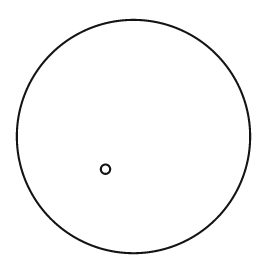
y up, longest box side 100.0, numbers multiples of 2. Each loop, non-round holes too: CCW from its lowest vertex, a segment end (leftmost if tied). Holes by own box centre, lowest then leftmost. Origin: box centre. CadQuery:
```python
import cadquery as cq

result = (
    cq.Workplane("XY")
    .moveTo(0.0, 0.0)
    .circle(50.0)
    .moveTo(-12.0, -14.0)
    .circle(2.0)
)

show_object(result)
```